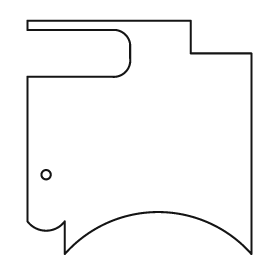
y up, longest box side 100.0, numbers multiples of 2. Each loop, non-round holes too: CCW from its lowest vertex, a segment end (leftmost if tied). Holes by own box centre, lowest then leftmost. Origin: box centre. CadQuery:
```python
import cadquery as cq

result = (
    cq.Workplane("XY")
    .moveTo(-32.0, -50.0)
    .threePointArc((8.0, -32.0), (48.0, -50.0))
    .lineTo(48.0, 36.0)
    .lineTo(22.0, 36.0)
    .lineTo(22.0, 50.0)
    .lineTo(-48.0, 50.0)
    .lineTo(-48.0, 46.0)
    .lineTo(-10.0, 46.0)
    .threePointArc((-6.0, 44.0), (-4.0, 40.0))
    .lineTo(-4.0, 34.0)
    .threePointArc((-6.0, 28.0), (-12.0, 26.0))
    .lineTo(-48.0, 26.0)
    .lineTo(-48.0, -36.0)
    .threePointArc((-40.0, -40.0), (-32.0, -36.0))
    .close()
    .moveTo(-40.0, -16.0)
    .circle(2.0)
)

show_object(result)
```